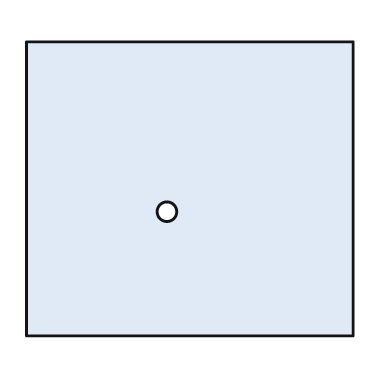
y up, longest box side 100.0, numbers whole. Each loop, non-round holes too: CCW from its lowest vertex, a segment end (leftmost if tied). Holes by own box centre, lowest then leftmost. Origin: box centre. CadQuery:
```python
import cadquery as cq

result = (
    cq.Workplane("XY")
    .moveTo(-50.0, -45.0)
    .lineTo(50.0, -45.0)
    .lineTo(50.0, 45.0)
    .lineTo(-50.0, 45.0)
    .close()
    .moveTo(-7.0, -7.0)
    .circle(3.0)
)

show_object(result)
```